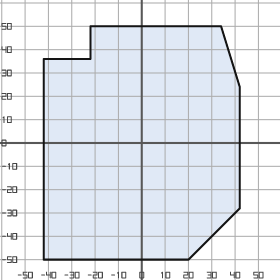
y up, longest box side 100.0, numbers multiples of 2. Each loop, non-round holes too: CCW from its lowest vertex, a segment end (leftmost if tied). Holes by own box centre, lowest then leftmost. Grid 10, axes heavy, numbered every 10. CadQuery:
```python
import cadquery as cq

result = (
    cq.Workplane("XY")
    .moveTo(-42.0, -50.0)
    .lineTo(20.0, -50.0)
    .lineTo(42.0, -28.0)
    .lineTo(42.0, 24.0)
    .lineTo(34.0, 50.0)
    .lineTo(-22.0, 50.0)
    .lineTo(-22.0, 36.0)
    .lineTo(-42.0, 36.0)
    .close()
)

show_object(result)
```